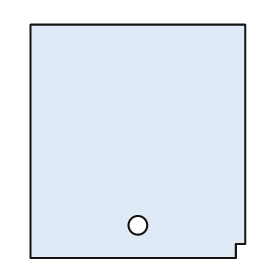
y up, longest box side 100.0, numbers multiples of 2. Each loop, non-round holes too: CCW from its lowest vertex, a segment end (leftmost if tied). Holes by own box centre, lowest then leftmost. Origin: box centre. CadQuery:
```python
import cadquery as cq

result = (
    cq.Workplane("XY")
    .moveTo(-46.0, -50.0)
    .lineTo(42.0, -50.0)
    .lineTo(42.0, -44.0)
    .lineTo(46.0, -44.0)
    .lineTo(46.0, 50.0)
    .lineTo(-46.0, 50.0)
    .close()
    .moveTo(0.0, -36.0)
    .circle(4.0)
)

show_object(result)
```